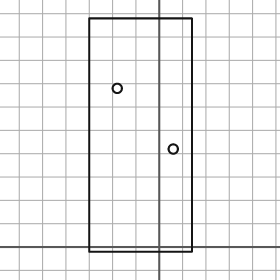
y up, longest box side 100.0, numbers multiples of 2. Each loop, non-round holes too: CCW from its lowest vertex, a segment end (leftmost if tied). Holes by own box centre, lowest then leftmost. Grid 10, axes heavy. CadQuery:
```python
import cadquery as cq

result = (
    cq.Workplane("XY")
    .moveTo(-30.0, -2.0)
    .lineTo(14.0, -2.0)
    .lineTo(14.0, 98.0)
    .lineTo(-30.0, 98.0)
    .close()
    .moveTo(6.0, 42.0)
    .circle(2.0)
    .moveTo(-18.0, 68.0)
    .circle(2.0)
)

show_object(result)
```